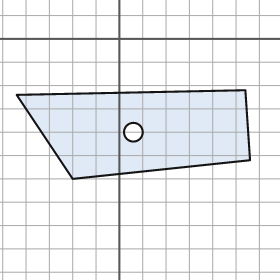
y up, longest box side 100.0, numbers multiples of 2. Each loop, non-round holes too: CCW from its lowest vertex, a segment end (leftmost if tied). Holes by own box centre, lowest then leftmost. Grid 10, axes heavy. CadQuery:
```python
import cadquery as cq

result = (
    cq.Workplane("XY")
    .moveTo(-20.0, -60.0)
    .lineTo(56.0, -52.0)
    .lineTo(54.0, -22.0)
    .lineTo(-44.0, -24.0)
    .close()
    .moveTo(6.0, -40.0)
    .circle(4.0)
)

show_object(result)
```